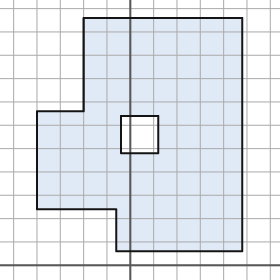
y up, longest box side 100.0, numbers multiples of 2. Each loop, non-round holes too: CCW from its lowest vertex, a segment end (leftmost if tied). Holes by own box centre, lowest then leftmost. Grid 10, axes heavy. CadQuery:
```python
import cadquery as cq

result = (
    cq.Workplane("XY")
    .moveTo(-6.0, 6.0)
    .lineTo(48.0, 6.0)
    .lineTo(48.0, 106.0)
    .lineTo(-20.0, 106.0)
    .lineTo(-20.0, 66.0)
    .lineTo(-40.0, 66.0)
    .lineTo(-40.0, 24.0)
    .lineTo(-6.0, 24.0)
    .close()
    .moveTo(-4.0, 48.0)
    .lineTo(12.0, 48.0)
    .lineTo(12.0, 64.0)
    .lineTo(-4.0, 64.0)
    .close()
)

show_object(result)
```